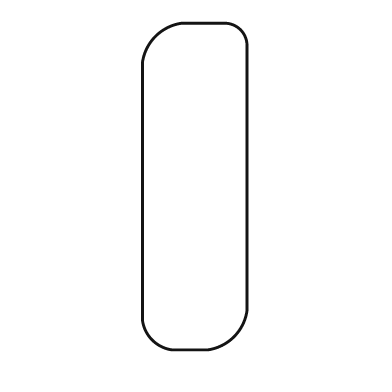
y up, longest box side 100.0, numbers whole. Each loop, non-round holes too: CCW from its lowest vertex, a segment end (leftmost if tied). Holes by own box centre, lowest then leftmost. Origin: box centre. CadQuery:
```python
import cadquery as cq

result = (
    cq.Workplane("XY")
    .moveTo(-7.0, -50.0)
    .lineTo(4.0, -50.0)
    .threePointArc((12.0, -46.0), (16.0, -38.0))
    .lineTo(16.0, 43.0)
    .threePointArc((14.0, 48.0), (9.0, 50.0))
    .lineTo(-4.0, 50.0)
    .threePointArc((-12.0, 46.0), (-16.0, 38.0))
    .lineTo(-16.0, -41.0)
    .threePointArc((-13.0, -47.0), (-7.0, -50.0))
    .close()
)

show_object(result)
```